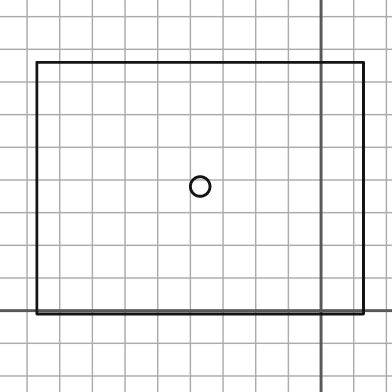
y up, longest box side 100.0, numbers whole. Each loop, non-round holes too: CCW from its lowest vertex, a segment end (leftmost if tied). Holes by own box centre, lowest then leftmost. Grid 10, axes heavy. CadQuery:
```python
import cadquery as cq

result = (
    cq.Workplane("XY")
    .moveTo(-87.0, -1.0)
    .lineTo(13.0, -1.0)
    .lineTo(13.0, 76.0)
    .lineTo(-87.0, 76.0)
    .close()
    .moveTo(-37.0, 38.0)
    .circle(3.0)
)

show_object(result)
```